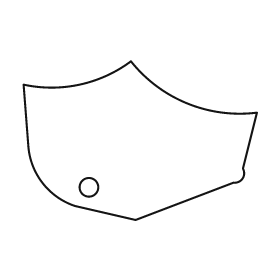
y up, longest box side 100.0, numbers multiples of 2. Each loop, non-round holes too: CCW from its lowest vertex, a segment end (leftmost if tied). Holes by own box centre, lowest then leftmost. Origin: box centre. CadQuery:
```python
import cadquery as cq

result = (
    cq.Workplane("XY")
    .moveTo(-2.0, -34.0)
    .lineTo(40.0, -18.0)
    .threePointArc((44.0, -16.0), (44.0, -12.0))
    .lineTo(50.0, 12.0)
    .threePointArc((20.0, 16.0), (-4.0, 34.0))
    .threePointArc((-26.0, 24.0), (-50.0, 24.0))
    .lineTo(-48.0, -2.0)
    .threePointArc((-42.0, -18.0), (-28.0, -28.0))
    .close()
    .moveTo(-22.0, -20.0)
    .circle(4.0)
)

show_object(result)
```